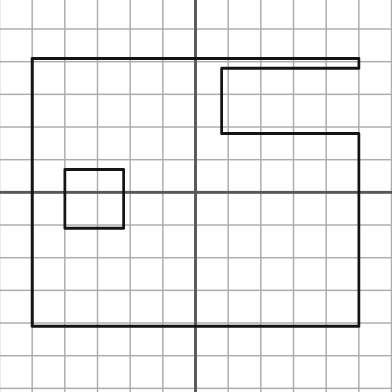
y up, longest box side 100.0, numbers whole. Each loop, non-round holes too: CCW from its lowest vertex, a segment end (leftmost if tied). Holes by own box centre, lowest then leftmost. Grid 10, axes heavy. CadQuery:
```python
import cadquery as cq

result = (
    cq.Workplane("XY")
    .moveTo(-50.0, -41.0)
    .lineTo(50.0, -41.0)
    .lineTo(50.0, 18.0)
    .lineTo(8.0, 18.0)
    .lineTo(8.0, 38.0)
    .lineTo(50.0, 38.0)
    .lineTo(50.0, 41.0)
    .lineTo(-50.0, 41.0)
    .close()
    .moveTo(-40.0, -11.0)
    .lineTo(-22.0, -11.0)
    .lineTo(-22.0, 7.0)
    .lineTo(-40.0, 7.0)
    .close()
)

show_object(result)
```